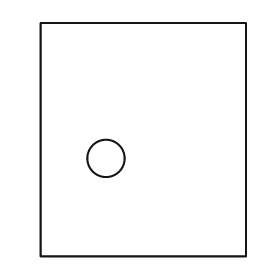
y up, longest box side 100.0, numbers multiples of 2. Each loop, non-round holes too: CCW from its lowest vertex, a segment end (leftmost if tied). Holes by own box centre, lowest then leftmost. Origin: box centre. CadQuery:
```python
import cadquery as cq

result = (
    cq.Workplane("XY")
    .moveTo(-44.0, -50.0)
    .lineTo(44.0, -50.0)
    .lineTo(44.0, 50.0)
    .lineTo(-44.0, 50.0)
    .close()
    .moveTo(-16.0, -8.0)
    .circle(8.0)
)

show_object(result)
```